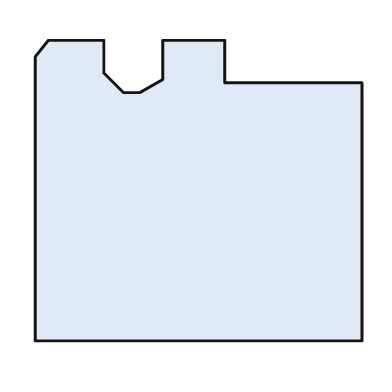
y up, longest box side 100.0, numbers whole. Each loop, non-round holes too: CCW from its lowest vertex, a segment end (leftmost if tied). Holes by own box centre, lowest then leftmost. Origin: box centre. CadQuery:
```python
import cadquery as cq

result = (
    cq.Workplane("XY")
    .moveTo(-50.0, -46.0)
    .lineTo(50.0, -46.0)
    .lineTo(50.0, 33.0)
    .lineTo(8.0, 33.0)
    .lineTo(8.0, 46.0)
    .lineTo(-11.0, 46.0)
    .lineTo(-11.0, 34.0)
    .lineTo(-18.0, 30.0)
    .lineTo(-23.0, 30.0)
    .lineTo(-29.0, 36.0)
    .lineTo(-29.0, 46.0)
    .lineTo(-46.0, 46.0)
    .lineTo(-50.0, 41.0)
    .close()
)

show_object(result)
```